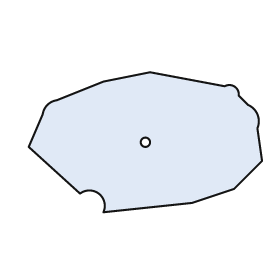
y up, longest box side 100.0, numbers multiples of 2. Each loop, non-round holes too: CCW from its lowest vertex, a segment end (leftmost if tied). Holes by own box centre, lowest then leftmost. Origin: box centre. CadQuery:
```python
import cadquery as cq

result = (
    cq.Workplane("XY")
    .moveTo(-18.0, -30.0)
    .lineTo(20.0, -26.0)
    .lineTo(38.0, -20.0)
    .lineTo(50.0, -8.0)
    .lineTo(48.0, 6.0)
    .threePointArc((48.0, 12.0), (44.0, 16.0))
    .lineTo(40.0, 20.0)
    .threePointArc((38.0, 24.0), (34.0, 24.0))
    .lineTo(2.0, 30.0)
    .lineTo(-18.0, 26.0)
    .lineTo(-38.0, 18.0)
    .threePointArc((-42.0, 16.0), (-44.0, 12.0))
    .lineTo(-50.0, -2.0)
    .lineTo(-28.0, -22.0)
    .threePointArc((-20.0, -22.0), (-18.0, -30.0))
    .close()
    .moveTo(0.0, 0.0)
    .circle(2.0)
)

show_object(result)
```